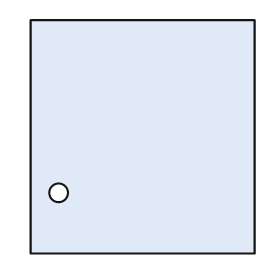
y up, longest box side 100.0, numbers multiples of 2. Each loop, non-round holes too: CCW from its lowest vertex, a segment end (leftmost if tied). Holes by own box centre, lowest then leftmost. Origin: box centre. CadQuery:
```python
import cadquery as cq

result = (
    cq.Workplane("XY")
    .moveTo(-48.0, -50.0)
    .lineTo(48.0, -50.0)
    .lineTo(48.0, 50.0)
    .lineTo(-48.0, 50.0)
    .close()
    .moveTo(-36.0, -24.0)
    .circle(4.0)
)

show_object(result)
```